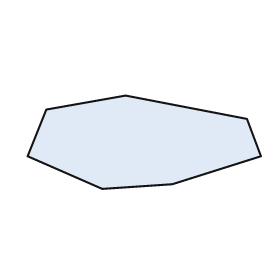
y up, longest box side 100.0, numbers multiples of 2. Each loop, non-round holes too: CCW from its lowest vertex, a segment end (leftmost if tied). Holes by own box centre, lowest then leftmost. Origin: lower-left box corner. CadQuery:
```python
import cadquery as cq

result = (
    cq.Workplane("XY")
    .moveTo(32.0, 0.0)
    .lineTo(62.0, 2.0)
    .lineTo(100.0, 14.0)
    .lineTo(94.0, 30.0)
    .lineTo(42.0, 40.0)
    .lineTo(8.0, 34.0)
    .lineTo(0.0, 14.0)
    .close()
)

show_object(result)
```